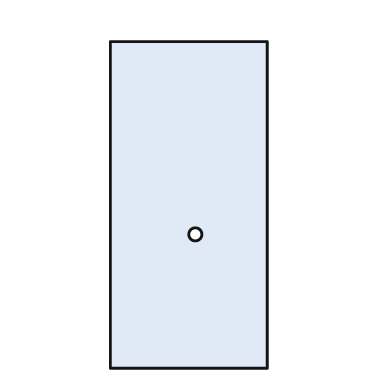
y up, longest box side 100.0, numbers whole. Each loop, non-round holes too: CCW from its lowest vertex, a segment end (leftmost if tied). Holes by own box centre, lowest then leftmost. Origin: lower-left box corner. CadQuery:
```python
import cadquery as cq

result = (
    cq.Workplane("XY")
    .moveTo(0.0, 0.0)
    .lineTo(48.0, 0.0)
    .lineTo(48.0, 100.0)
    .lineTo(0.0, 100.0)
    .close()
    .moveTo(26.0, 41.0)
    .circle(2.0)
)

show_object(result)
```